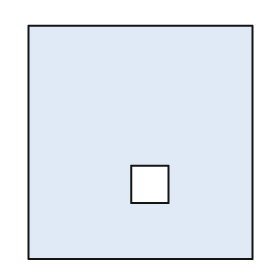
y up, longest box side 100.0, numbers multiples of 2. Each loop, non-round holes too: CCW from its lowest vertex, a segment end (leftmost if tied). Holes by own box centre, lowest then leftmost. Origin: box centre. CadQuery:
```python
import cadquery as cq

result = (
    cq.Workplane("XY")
    .moveTo(-48.0, -50.0)
    .lineTo(48.0, -50.0)
    .lineTo(48.0, 50.0)
    .lineTo(-48.0, 50.0)
    .close()
    .moveTo(-4.0, -26.0)
    .lineTo(12.0, -26.0)
    .lineTo(12.0, -10.0)
    .lineTo(-4.0, -10.0)
    .close()
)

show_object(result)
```